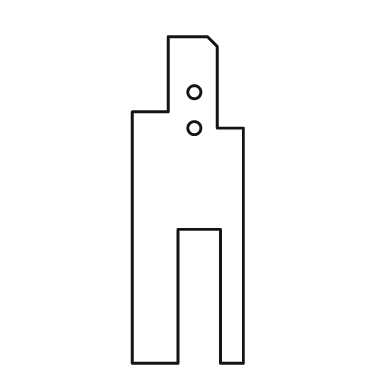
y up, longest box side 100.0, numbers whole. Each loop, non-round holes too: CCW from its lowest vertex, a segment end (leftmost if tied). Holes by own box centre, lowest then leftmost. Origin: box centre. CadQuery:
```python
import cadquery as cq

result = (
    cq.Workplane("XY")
    .moveTo(-17.0, -50.0)
    .lineTo(-3.0, -50.0)
    .lineTo(-3.0, -9.0)
    .lineTo(10.0, -9.0)
    .lineTo(10.0, -50.0)
    .lineTo(17.0, -50.0)
    .lineTo(17.0, 22.0)
    .lineTo(9.0, 22.0)
    .lineTo(9.0, 47.0)
    .lineTo(6.0, 50.0)
    .lineTo(-6.0, 50.0)
    .lineTo(-6.0, 27.0)
    .lineTo(-17.0, 27.0)
    .close()
    .moveTo(2.0, 22.0)
    .circle(2.0)
    .moveTo(2.0, 33.0)
    .circle(2.0)
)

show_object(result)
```